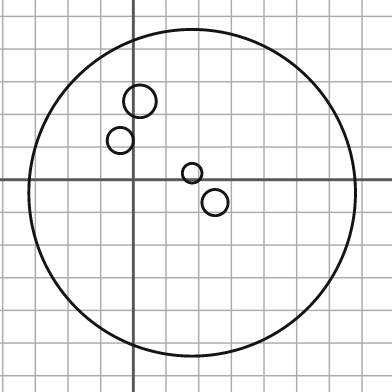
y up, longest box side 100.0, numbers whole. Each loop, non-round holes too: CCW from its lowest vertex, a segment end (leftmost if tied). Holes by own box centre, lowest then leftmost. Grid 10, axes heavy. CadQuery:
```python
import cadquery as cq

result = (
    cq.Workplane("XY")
    .moveTo(18.0, -4.0)
    .circle(50.0)
    .moveTo(25.0, -7.0)
    .circle(4.0)
    .moveTo(18.0, 2.0)
    .circle(3.0)
    .moveTo(-4.0, 12.0)
    .circle(4.0)
    .moveTo(2.0, 24.0)
    .circle(5.0)
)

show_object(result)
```